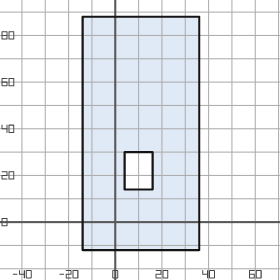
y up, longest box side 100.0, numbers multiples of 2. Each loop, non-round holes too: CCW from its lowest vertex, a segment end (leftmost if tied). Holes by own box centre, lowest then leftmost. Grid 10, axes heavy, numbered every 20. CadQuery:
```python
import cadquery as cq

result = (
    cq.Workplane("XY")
    .moveTo(-14.0, -12.0)
    .lineTo(36.0, -12.0)
    .lineTo(36.0, 88.0)
    .lineTo(-14.0, 88.0)
    .close()
    .moveTo(4.0, 14.0)
    .lineTo(16.0, 14.0)
    .lineTo(16.0, 30.0)
    .lineTo(4.0, 30.0)
    .close()
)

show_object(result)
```